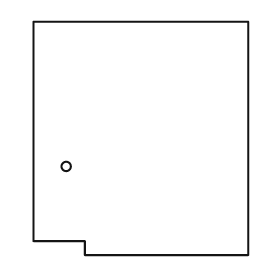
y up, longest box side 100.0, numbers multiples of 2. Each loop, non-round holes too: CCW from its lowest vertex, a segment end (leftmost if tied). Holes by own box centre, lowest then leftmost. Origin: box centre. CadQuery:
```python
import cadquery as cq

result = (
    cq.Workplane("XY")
    .moveTo(-24.0, -50.0)
    .lineTo(46.0, -50.0)
    .lineTo(46.0, 50.0)
    .lineTo(-46.0, 50.0)
    .lineTo(-46.0, -44.0)
    .lineTo(-24.0, -44.0)
    .close()
    .moveTo(-32.0, -12.0)
    .circle(2.0)
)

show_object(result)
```